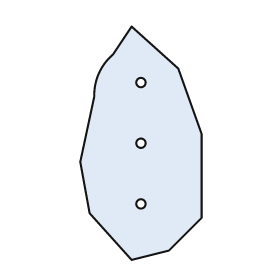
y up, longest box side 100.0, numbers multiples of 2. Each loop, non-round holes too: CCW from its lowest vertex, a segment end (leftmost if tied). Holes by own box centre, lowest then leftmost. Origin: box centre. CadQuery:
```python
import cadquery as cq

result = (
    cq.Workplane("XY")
    .moveTo(-4.0, -50.0)
    .lineTo(12.0, -46.0)
    .lineTo(26.0, -32.0)
    .lineTo(26.0, 4.0)
    .lineTo(16.0, 32.0)
    .lineTo(-4.0, 50.0)
    .lineTo(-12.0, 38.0)
    .threePointArc((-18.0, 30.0), (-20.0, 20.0))
    .lineTo(-26.0, -8.0)
    .lineTo(-22.0, -30.0)
    .close()
    .moveTo(0.0, -26.0)
    .circle(2.0)
    .moveTo(0.0, 0.0)
    .circle(2.0)
    .moveTo(0.0, 26.0)
    .circle(2.0)
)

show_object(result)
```